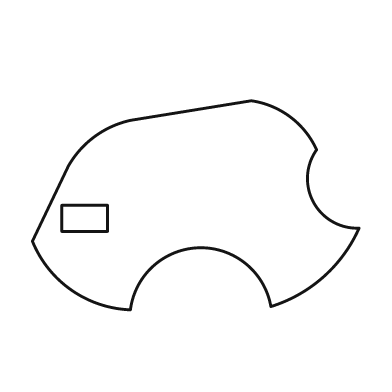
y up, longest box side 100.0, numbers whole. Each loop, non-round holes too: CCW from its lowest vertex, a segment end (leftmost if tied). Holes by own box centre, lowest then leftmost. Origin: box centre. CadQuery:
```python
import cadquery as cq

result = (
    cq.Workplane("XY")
    .moveTo(-20.0, -32.0)
    .threePointArc((1.0, -13.0), (23.0, -31.0))
    .threePointArc((39.0, -22.0), (50.0, -7.0))
    .threePointArc((36.0, 1.0), (37.0, 17.0))
    .threePointArc((29.0, 27.0), (17.0, 32.0))
    .lineTo(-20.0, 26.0)
    .threePointArc((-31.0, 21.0), (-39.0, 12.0))
    .lineTo(-50.0, -11.0)
    .threePointArc((-38.0, -26.0), (-20.0, -32.0))
    .close()
    .moveTo(-41.0, -8.0)
    .lineTo(-27.0, -8.0)
    .lineTo(-27.0, 0.0)
    .lineTo(-41.0, 0.0)
    .close()
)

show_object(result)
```